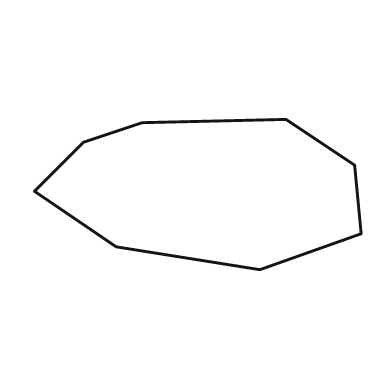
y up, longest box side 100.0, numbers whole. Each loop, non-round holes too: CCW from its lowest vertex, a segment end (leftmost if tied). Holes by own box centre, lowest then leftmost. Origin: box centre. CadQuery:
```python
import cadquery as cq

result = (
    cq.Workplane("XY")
    .moveTo(19.0, -23.0)
    .lineTo(50.0, -12.0)
    .lineTo(48.0, 9.0)
    .lineTo(27.0, 23.0)
    .lineTo(-17.0, 22.0)
    .lineTo(-35.0, 16.0)
    .lineTo(-50.0, 1.0)
    .lineTo(-25.0, -16.0)
    .close()
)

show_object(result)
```